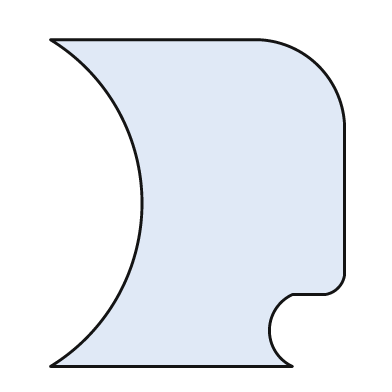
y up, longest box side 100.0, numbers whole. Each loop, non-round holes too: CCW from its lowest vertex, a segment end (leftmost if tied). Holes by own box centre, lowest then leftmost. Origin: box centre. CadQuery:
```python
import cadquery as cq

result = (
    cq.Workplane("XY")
    .moveTo(-45.0, -50.0)
    .lineTo(29.0, -50.0)
    .threePointArc((22.0, -39.0), (29.0, -28.0))
    .lineTo(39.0, -28.0)
    .threePointArc((43.0, -26.0), (45.0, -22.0))
    .lineTo(45.0, 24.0)
    .threePointArc((37.0, 42.0), (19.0, 50.0))
    .lineTo(-45.0, 50.0)
    .threePointArc((-17.0, 0.0), (-45.0, -50.0))
    .close()
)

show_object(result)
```